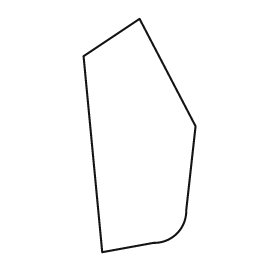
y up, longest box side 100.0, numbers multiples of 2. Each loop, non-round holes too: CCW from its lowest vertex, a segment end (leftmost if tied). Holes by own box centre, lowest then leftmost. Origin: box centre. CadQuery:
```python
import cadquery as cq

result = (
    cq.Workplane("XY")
    .moveTo(-16.0, -50.0)
    .lineTo(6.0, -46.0)
    .threePointArc((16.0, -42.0), (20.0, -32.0))
    .lineTo(24.0, 4.0)
    .lineTo(0.0, 50.0)
    .lineTo(-24.0, 34.0)
    .close()
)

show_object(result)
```